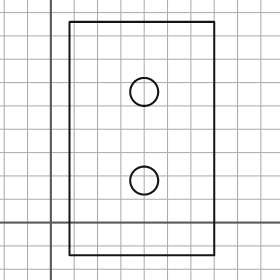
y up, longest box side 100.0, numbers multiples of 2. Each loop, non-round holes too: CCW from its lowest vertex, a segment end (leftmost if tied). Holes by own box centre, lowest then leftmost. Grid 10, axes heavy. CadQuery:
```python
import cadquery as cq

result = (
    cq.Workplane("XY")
    .moveTo(8.0, -14.0)
    .lineTo(70.0, -14.0)
    .lineTo(70.0, 86.0)
    .lineTo(8.0, 86.0)
    .close()
    .moveTo(40.0, 18.0)
    .circle(6.0)
    .moveTo(40.0, 56.0)
    .circle(6.0)
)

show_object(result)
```